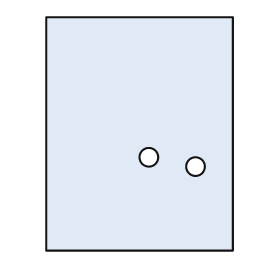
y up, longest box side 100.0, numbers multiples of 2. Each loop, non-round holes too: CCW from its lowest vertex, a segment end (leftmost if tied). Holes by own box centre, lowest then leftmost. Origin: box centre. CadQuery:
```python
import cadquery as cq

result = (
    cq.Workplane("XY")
    .moveTo(-40.0, -50.0)
    .lineTo(40.0, -50.0)
    .lineTo(40.0, 50.0)
    .lineTo(-40.0, 50.0)
    .close()
    .moveTo(24.0, -14.0)
    .circle(4.0)
    .moveTo(4.0, -10.0)
    .circle(4.0)
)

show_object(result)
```